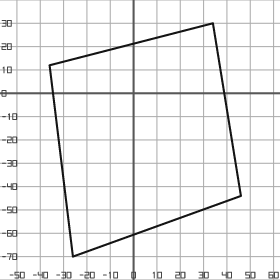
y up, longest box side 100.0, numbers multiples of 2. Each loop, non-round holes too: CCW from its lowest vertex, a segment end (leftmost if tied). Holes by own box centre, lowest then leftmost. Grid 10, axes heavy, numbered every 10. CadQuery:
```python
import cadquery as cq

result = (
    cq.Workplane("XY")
    .moveTo(-26.0, -70.0)
    .lineTo(46.0, -44.0)
    .lineTo(34.0, 30.0)
    .lineTo(-36.0, 12.0)
    .close()
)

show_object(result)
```